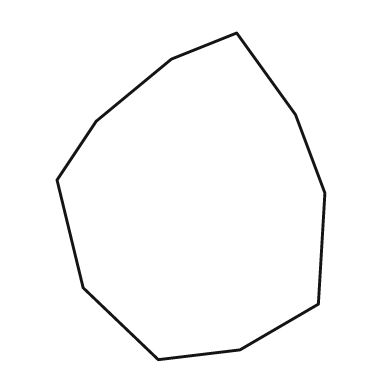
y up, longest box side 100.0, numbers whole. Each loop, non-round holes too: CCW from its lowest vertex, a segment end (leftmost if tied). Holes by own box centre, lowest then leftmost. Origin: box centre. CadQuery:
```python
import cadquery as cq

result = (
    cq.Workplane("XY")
    .moveTo(-10.0, -50.0)
    .lineTo(15.0, -47.0)
    .lineTo(39.0, -33.0)
    .lineTo(41.0, 1.0)
    .lineTo(32.0, 25.0)
    .lineTo(14.0, 50.0)
    .lineTo(-6.0, 42.0)
    .lineTo(-29.0, 23.0)
    .lineTo(-41.0, 5.0)
    .lineTo(-33.0, -28.0)
    .close()
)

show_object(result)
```